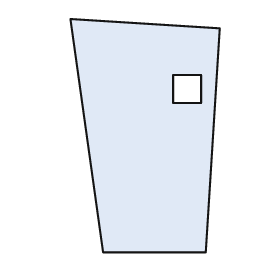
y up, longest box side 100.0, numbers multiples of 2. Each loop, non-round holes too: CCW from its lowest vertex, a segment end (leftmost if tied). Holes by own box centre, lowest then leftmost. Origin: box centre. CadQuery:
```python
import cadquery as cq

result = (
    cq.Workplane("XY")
    .moveTo(-18.0, -50.0)
    .lineTo(26.0, -50.0)
    .lineTo(32.0, 46.0)
    .lineTo(-32.0, 50.0)
    .close()
    .moveTo(12.0, 14.0)
    .lineTo(24.0, 14.0)
    .lineTo(24.0, 26.0)
    .lineTo(12.0, 26.0)
    .close()
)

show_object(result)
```